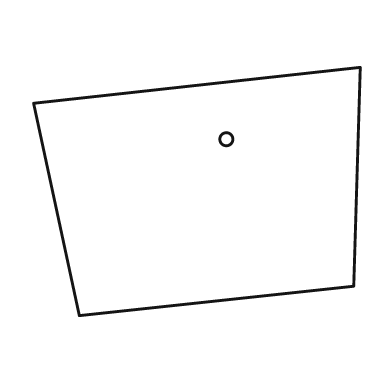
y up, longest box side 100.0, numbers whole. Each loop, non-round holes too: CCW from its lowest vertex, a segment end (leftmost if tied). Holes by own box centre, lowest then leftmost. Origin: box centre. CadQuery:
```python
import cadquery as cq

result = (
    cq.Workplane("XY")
    .moveTo(-36.0, -38.0)
    .lineTo(48.0, -29.0)
    .lineTo(50.0, 38.0)
    .lineTo(-50.0, 27.0)
    .close()
    .moveTo(9.0, 16.0)
    .circle(2.0)
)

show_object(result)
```